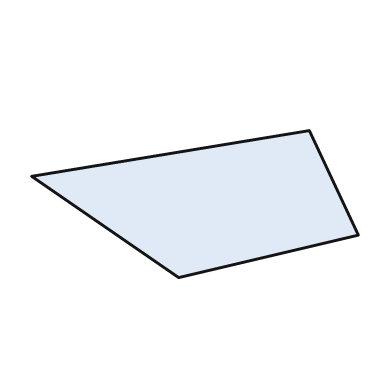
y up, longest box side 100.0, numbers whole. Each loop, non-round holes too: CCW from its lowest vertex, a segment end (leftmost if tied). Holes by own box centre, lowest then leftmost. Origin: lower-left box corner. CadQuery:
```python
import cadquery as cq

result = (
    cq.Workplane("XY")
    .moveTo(45.0, 0.0)
    .lineTo(100.0, 13.0)
    .lineTo(85.0, 45.0)
    .lineTo(0.0, 31.0)
    .close()
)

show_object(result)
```